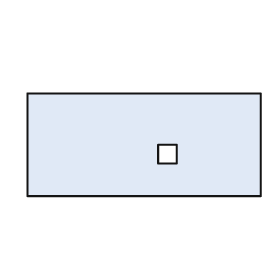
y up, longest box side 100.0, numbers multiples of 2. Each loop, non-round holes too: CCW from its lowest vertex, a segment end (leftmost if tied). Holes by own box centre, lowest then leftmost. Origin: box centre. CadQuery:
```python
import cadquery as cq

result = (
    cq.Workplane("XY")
    .moveTo(-50.0, -22.0)
    .lineTo(50.0, -22.0)
    .lineTo(50.0, 22.0)
    .lineTo(-50.0, 22.0)
    .close()
    .moveTo(6.0, -8.0)
    .lineTo(14.0, -8.0)
    .lineTo(14.0, 0.0)
    .lineTo(6.0, 0.0)
    .close()
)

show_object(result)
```